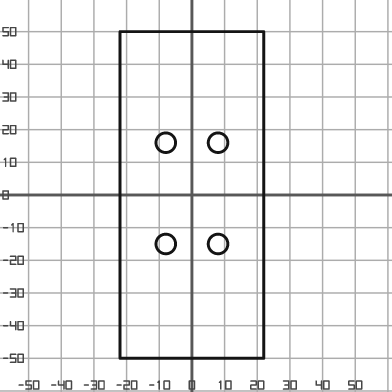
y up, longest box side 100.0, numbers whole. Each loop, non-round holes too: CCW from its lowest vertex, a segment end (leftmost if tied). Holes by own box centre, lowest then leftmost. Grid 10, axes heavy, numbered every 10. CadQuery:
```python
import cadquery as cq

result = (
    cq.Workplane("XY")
    .moveTo(-22.0, -50.0)
    .lineTo(22.0, -50.0)
    .lineTo(22.0, 50.0)
    .lineTo(-22.0, 50.0)
    .close()
    .moveTo(-8.0, -15.0)
    .circle(3.0)
    .moveTo(8.0, -15.0)
    .circle(3.0)
    .moveTo(-8.0, 16.0)
    .circle(3.0)
    .moveTo(8.0, 16.0)
    .circle(3.0)
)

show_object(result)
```